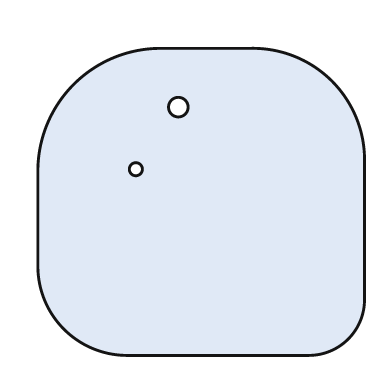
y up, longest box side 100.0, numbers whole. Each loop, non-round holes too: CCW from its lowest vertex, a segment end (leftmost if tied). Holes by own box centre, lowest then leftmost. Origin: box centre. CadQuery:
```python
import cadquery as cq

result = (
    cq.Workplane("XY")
    .moveTo(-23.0, -47.0)
    .lineTo(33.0, -47.0)
    .threePointArc((45.0, -42.0), (50.0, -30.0))
    .lineTo(50.0, 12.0)
    .threePointArc((40.0, 37.0), (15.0, 47.0))
    .lineTo(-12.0, 47.0)
    .threePointArc((-39.0, 36.0), (-50.0, 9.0))
    .lineTo(-50.0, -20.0)
    .threePointArc((-42.0, -39.0), (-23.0, -47.0))
    .close()
    .moveTo(-20.0, 10.0)
    .circle(2.0)
    .moveTo(-7.0, 29.0)
    .circle(3.0)
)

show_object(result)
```